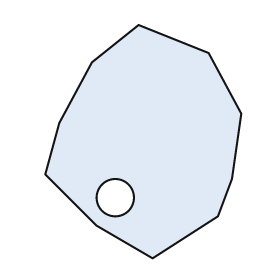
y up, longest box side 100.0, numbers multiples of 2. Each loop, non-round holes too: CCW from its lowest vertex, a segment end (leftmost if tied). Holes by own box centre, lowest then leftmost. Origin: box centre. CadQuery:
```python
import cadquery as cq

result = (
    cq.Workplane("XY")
    .moveTo(4.0, -50.0)
    .lineTo(32.0, -32.0)
    .lineTo(38.0, -16.0)
    .lineTo(42.0, 12.0)
    .lineTo(28.0, 38.0)
    .lineTo(-2.0, 50.0)
    .lineTo(-22.0, 34.0)
    .lineTo(-36.0, 8.0)
    .lineTo(-42.0, -14.0)
    .lineTo(-20.0, -36.0)
    .close()
    .moveTo(-12.0, -24.0)
    .circle(8.0)
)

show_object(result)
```